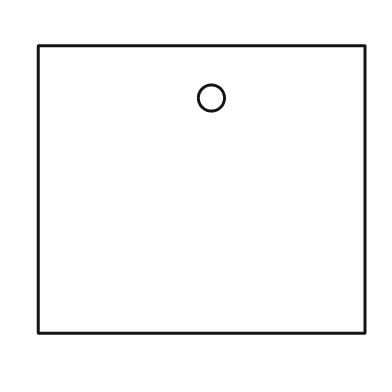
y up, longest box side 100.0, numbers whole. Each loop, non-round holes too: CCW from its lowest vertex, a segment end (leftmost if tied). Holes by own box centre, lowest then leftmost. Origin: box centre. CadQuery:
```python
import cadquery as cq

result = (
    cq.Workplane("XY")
    .moveTo(-50.0, -44.0)
    .lineTo(50.0, -44.0)
    .lineTo(50.0, 44.0)
    .lineTo(-50.0, 44.0)
    .close()
    .moveTo(3.0, 28.0)
    .circle(4.0)
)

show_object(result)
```